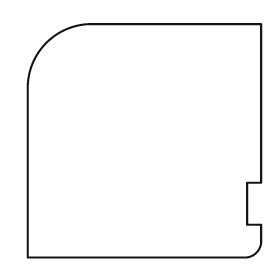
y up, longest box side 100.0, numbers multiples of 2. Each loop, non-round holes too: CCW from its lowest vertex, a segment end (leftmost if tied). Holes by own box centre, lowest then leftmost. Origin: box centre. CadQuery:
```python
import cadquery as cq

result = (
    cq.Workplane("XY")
    .moveTo(-50.0, -50.0)
    .lineTo(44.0, -50.0)
    .threePointArc((48.0, -48.0), (50.0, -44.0))
    .lineTo(50.0, -36.0)
    .lineTo(44.0, -36.0)
    .lineTo(44.0, -18.0)
    .lineTo(50.0, -18.0)
    .lineTo(50.0, 50.0)
    .lineTo(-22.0, 50.0)
    .threePointArc((-42.0, 42.0), (-50.0, 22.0))
    .close()
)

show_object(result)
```